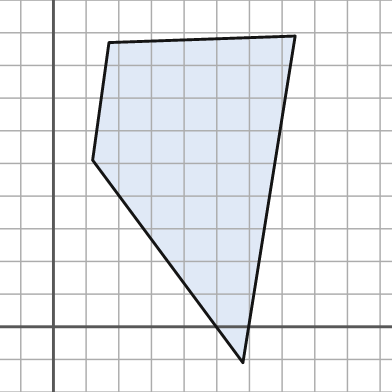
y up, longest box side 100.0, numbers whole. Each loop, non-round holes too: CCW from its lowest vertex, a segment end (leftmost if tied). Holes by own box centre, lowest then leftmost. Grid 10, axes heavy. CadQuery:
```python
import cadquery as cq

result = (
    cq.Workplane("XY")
    .moveTo(58.0, -11.0)
    .lineTo(74.0, 89.0)
    .lineTo(17.0, 87.0)
    .lineTo(12.0, 51.0)
    .close()
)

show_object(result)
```